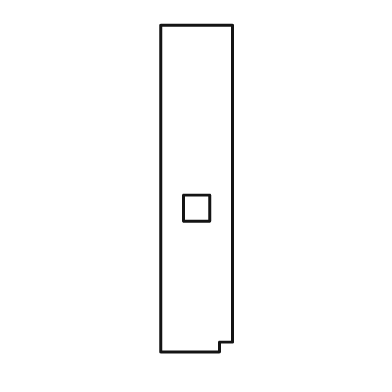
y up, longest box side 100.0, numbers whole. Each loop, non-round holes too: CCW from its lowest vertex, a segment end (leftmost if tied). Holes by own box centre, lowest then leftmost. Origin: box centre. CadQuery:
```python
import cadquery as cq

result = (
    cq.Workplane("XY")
    .moveTo(-11.0, -50.0)
    .lineTo(7.0, -50.0)
    .lineTo(7.0, -47.0)
    .lineTo(11.0, -47.0)
    .lineTo(11.0, 50.0)
    .lineTo(-11.0, 50.0)
    .close()
    .moveTo(-4.0, -10.0)
    .lineTo(4.0, -10.0)
    .lineTo(4.0, -2.0)
    .lineTo(-4.0, -2.0)
    .close()
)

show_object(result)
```